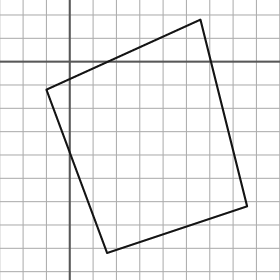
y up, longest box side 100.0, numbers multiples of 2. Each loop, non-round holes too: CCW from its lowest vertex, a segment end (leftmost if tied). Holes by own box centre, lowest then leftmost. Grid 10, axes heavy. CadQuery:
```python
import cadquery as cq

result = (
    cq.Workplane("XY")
    .moveTo(16.0, -82.0)
    .lineTo(76.0, -62.0)
    .lineTo(56.0, 18.0)
    .lineTo(-10.0, -12.0)
    .close()
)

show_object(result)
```